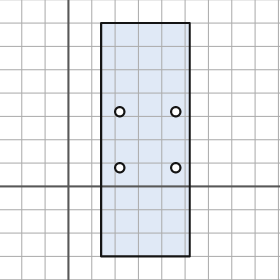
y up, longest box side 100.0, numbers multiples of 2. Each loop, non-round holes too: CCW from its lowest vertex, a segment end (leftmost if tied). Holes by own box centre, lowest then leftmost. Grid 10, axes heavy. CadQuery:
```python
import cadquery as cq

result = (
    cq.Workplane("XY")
    .moveTo(14.0, -30.0)
    .lineTo(52.0, -30.0)
    .lineTo(52.0, 70.0)
    .lineTo(14.0, 70.0)
    .close()
    .moveTo(22.0, 8.0)
    .circle(2.0)
    .moveTo(46.0, 8.0)
    .circle(2.0)
    .moveTo(22.0, 32.0)
    .circle(2.0)
    .moveTo(46.0, 32.0)
    .circle(2.0)
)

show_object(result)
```